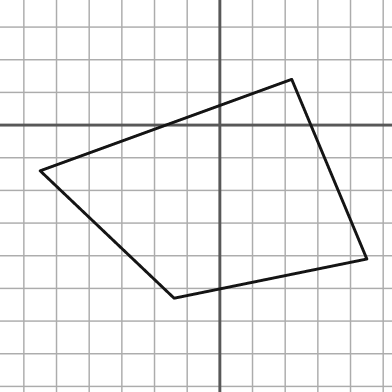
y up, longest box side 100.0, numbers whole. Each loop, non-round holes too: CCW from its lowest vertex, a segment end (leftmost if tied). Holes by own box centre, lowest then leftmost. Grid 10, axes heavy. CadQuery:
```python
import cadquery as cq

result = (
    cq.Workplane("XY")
    .moveTo(-14.0, -53.0)
    .lineTo(45.0, -41.0)
    .lineTo(22.0, 14.0)
    .lineTo(-55.0, -14.0)
    .close()
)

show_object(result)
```